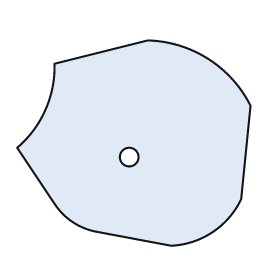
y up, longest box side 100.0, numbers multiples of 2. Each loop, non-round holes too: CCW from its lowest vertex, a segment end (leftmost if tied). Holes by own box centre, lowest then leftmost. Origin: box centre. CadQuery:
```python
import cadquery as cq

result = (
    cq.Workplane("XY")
    .moveTo(16.0, -44.0)
    .threePointArc((34.0, -38.0), (46.0, -24.0))
    .lineTo(50.0, 16.0)
    .threePointArc((32.0, 36.0), (6.0, 44.0))
    .lineTo(-34.0, 34.0)
    .threePointArc((-38.0, 14.0), (-50.0, -2.0))
    .lineTo(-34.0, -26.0)
    .threePointArc((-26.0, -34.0), (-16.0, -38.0))
    .close()
    .moveTo(-2.0, -6.0)
    .circle(4.0)
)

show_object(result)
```